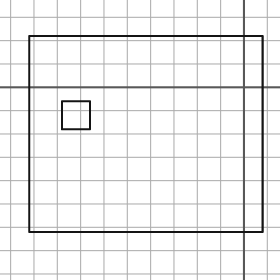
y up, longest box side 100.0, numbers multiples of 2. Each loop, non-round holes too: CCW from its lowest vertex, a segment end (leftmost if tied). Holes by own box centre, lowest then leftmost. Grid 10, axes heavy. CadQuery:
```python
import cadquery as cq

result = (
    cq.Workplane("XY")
    .moveTo(-92.0, -62.0)
    .lineTo(8.0, -62.0)
    .lineTo(8.0, 22.0)
    .lineTo(-92.0, 22.0)
    .close()
    .moveTo(-78.0, -18.0)
    .lineTo(-66.0, -18.0)
    .lineTo(-66.0, -6.0)
    .lineTo(-78.0, -6.0)
    .close()
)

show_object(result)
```